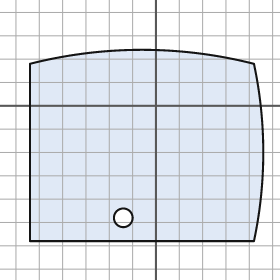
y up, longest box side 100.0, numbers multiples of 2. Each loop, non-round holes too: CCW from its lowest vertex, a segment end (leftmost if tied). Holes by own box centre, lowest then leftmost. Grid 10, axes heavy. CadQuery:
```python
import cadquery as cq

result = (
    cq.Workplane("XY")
    .moveTo(-54.0, -58.0)
    .lineTo(42.0, -58.0)
    .threePointArc((46.0, -20.0), (42.0, 18.0))
    .threePointArc((-6.0, 24.0), (-54.0, 18.0))
    .close()
    .moveTo(-14.0, -48.0)
    .circle(4.0)
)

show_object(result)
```